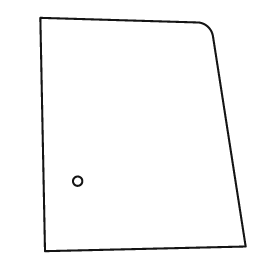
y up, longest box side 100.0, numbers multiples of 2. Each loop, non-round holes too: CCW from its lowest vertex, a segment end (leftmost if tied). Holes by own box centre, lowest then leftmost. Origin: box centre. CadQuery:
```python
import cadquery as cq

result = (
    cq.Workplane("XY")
    .moveTo(-42.0, -50.0)
    .lineTo(44.0, -48.0)
    .lineTo(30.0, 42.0)
    .threePointArc((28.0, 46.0), (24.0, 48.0))
    .lineTo(-44.0, 50.0)
    .close()
    .moveTo(-28.0, -20.0)
    .circle(2.0)
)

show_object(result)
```